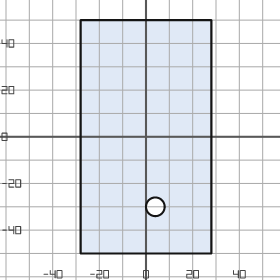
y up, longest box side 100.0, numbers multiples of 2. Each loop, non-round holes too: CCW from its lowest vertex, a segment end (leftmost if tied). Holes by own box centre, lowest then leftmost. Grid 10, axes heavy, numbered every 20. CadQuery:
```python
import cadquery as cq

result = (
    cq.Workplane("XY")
    .moveTo(-28.0, -50.0)
    .lineTo(28.0, -50.0)
    .lineTo(28.0, 50.0)
    .lineTo(-28.0, 50.0)
    .close()
    .moveTo(4.0, -30.0)
    .circle(4.0)
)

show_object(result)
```